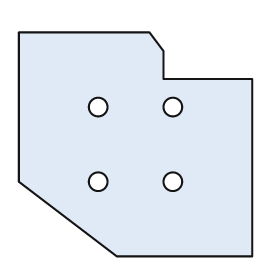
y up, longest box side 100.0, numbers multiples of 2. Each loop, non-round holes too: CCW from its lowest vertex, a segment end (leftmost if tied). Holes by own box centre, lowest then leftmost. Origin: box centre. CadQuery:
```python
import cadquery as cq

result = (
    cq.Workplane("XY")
    .moveTo(-8.0, -48.0)
    .lineTo(50.0, -48.0)
    .lineTo(50.0, 28.0)
    .lineTo(12.0, 28.0)
    .lineTo(12.0, 40.0)
    .lineTo(6.0, 48.0)
    .lineTo(-50.0, 48.0)
    .lineTo(-50.0, -16.0)
    .close()
    .moveTo(-16.0, -16.0)
    .circle(4.0)
    .moveTo(16.0, -16.0)
    .circle(4.0)
    .moveTo(-16.0, 16.0)
    .circle(4.0)
    .moveTo(16.0, 16.0)
    .circle(4.0)
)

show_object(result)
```